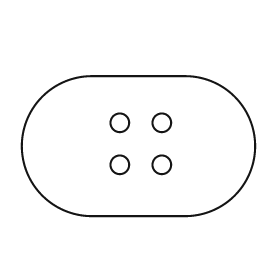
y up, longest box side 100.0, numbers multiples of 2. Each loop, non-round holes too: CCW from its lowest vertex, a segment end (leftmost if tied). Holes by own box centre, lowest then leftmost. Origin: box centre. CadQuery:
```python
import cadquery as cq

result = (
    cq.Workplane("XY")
    .moveTo(-20.0, -30.0)
    .lineTo(20.0, -30.0)
    .threePointArc((50.0, 0.0), (20.0, 30.0))
    .lineTo(-20.0, 30.0)
    .threePointArc((-50.0, 0.0), (-20.0, -30.0))
    .close()
    .moveTo(-8.0, -8.0)
    .circle(4.0)
    .moveTo(10.0, -8.0)
    .circle(4.0)
    .moveTo(-8.0, 10.0)
    .circle(4.0)
    .moveTo(10.0, 10.0)
    .circle(4.0)
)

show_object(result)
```